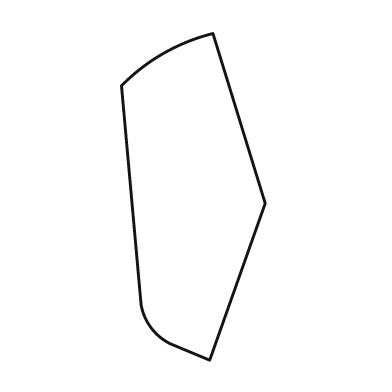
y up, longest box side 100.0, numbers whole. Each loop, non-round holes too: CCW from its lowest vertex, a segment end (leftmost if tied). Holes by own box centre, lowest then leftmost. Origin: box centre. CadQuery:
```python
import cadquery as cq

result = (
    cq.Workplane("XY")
    .moveTo(5.0, -50.0)
    .lineTo(22.0, -2.0)
    .lineTo(6.0, 50.0)
    .threePointArc((-9.0, 44.0), (-22.0, 34.0))
    .lineTo(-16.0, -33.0)
    .threePointArc((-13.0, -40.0), (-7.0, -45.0))
    .close()
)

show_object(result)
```